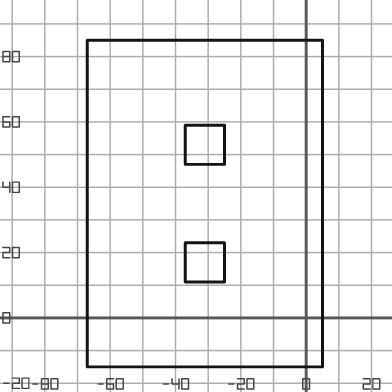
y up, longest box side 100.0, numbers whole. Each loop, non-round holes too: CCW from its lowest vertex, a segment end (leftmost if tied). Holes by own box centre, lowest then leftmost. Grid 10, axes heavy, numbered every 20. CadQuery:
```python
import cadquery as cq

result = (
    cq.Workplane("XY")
    .moveTo(-67.0, -15.0)
    .lineTo(5.0, -15.0)
    .lineTo(5.0, 85.0)
    .lineTo(-67.0, 85.0)
    .close()
    .moveTo(-37.0, 11.0)
    .lineTo(-25.0, 11.0)
    .lineTo(-25.0, 23.0)
    .lineTo(-37.0, 23.0)
    .close()
    .moveTo(-37.0, 47.0)
    .lineTo(-25.0, 47.0)
    .lineTo(-25.0, 59.0)
    .lineTo(-37.0, 59.0)
    .close()
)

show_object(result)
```